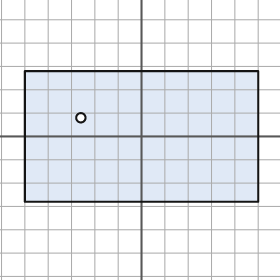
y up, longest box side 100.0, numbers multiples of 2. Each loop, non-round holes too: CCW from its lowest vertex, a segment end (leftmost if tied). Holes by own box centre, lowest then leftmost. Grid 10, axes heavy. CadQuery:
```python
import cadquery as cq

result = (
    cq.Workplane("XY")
    .moveTo(-50.0, -28.0)
    .lineTo(50.0, -28.0)
    .lineTo(50.0, 28.0)
    .lineTo(-50.0, 28.0)
    .close()
    .moveTo(-26.0, 8.0)
    .circle(2.0)
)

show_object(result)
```